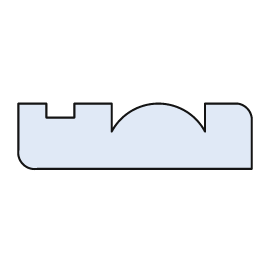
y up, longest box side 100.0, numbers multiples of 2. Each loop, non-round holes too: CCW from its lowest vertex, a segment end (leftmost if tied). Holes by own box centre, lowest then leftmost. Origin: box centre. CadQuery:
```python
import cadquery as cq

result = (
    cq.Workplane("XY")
    .moveTo(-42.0, -14.0)
    .lineTo(50.0, -14.0)
    .lineTo(50.0, 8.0)
    .threePointArc((48.0, 12.0), (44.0, 14.0))
    .lineTo(30.0, 14.0)
    .lineTo(30.0, 2.0)
    .threePointArc((10.0, 14.0), (-10.0, 2.0))
    .lineTo(-10.0, 14.0)
    .lineTo(-26.0, 14.0)
    .lineTo(-26.0, 8.0)
    .lineTo(-38.0, 8.0)
    .lineTo(-38.0, 14.0)
    .lineTo(-50.0, 14.0)
    .lineTo(-50.0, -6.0)
    .threePointArc((-48.0, -12.0), (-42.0, -14.0))
    .close()
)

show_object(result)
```